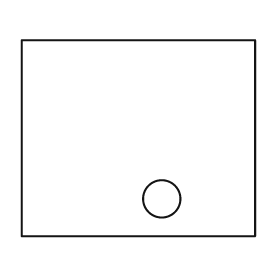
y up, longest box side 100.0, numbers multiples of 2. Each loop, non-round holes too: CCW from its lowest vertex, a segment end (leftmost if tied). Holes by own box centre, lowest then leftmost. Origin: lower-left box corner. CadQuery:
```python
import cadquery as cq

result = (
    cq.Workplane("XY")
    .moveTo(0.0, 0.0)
    .lineTo(100.0, 0.0)
    .lineTo(100.0, 84.0)
    .lineTo(0.0, 84.0)
    .close()
    .moveTo(60.0, 16.0)
    .circle(8.0)
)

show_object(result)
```